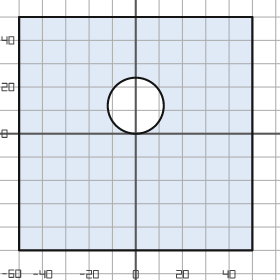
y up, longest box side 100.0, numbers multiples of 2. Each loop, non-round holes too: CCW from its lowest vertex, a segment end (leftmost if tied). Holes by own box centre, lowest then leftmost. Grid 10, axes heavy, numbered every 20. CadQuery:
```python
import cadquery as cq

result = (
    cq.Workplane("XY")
    .moveTo(-50.0, -50.0)
    .lineTo(50.0, -50.0)
    .lineTo(50.0, 50.0)
    .lineTo(-50.0, 50.0)
    .close()
    .moveTo(0.0, 12.0)
    .circle(12.0)
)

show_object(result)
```